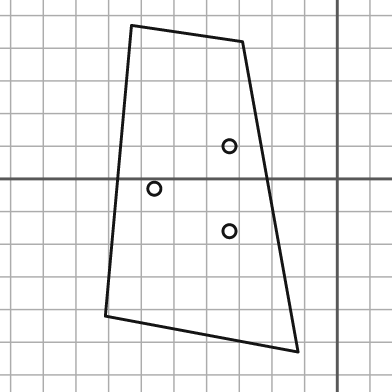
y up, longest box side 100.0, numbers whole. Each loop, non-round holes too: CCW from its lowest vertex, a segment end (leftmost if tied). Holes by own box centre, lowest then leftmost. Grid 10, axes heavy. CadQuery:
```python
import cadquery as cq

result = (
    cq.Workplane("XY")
    .moveTo(-12.0, -53.0)
    .lineTo(-29.0, 42.0)
    .lineTo(-63.0, 47.0)
    .lineTo(-71.0, -42.0)
    .close()
    .moveTo(-33.0, -16.0)
    .circle(2.0)
    .moveTo(-56.0, -3.0)
    .circle(2.0)
    .moveTo(-33.0, 10.0)
    .circle(2.0)
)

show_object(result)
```